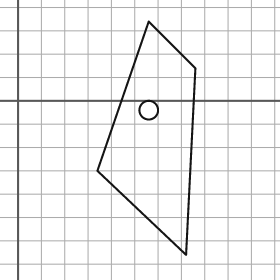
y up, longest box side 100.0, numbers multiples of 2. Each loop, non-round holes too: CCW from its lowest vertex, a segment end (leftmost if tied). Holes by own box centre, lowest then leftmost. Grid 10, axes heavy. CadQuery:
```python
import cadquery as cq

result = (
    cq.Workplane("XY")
    .moveTo(72.0, -66.0)
    .lineTo(76.0, 14.0)
    .lineTo(56.0, 34.0)
    .lineTo(34.0, -30.0)
    .close()
    .moveTo(56.0, -4.0)
    .circle(4.0)
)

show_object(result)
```